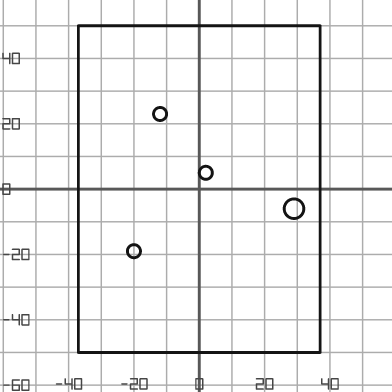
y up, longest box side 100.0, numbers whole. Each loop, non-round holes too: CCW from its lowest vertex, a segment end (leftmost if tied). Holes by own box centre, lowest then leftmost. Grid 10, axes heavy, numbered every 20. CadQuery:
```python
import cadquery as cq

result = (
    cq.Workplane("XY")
    .moveTo(-37.0, -50.0)
    .lineTo(37.0, -50.0)
    .lineTo(37.0, 50.0)
    .lineTo(-37.0, 50.0)
    .close()
    .moveTo(-20.0, -19.0)
    .circle(2.0)
    .moveTo(29.0, -6.0)
    .circle(3.0)
    .moveTo(2.0, 5.0)
    .circle(2.0)
    .moveTo(-12.0, 23.0)
    .circle(2.0)
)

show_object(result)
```